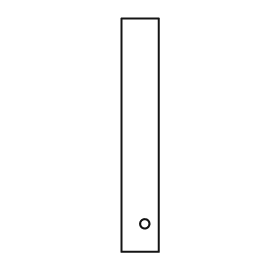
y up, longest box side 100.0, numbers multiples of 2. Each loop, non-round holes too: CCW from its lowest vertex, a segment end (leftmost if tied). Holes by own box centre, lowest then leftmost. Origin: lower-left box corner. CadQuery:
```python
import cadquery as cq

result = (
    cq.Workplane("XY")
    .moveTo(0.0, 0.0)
    .lineTo(16.0, 0.0)
    .lineTo(16.0, 100.0)
    .lineTo(0.0, 100.0)
    .close()
    .moveTo(10.0, 12.0)
    .circle(2.0)
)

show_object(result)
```